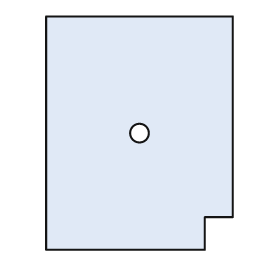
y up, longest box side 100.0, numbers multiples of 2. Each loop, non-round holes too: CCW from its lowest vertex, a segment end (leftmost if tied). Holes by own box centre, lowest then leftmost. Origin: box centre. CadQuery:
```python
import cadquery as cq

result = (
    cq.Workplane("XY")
    .moveTo(-40.0, -50.0)
    .lineTo(28.0, -50.0)
    .lineTo(28.0, -36.0)
    .lineTo(40.0, -36.0)
    .lineTo(40.0, 50.0)
    .lineTo(-40.0, 50.0)
    .close()
    .moveTo(0.0, 0.0)
    .circle(4.0)
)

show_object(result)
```